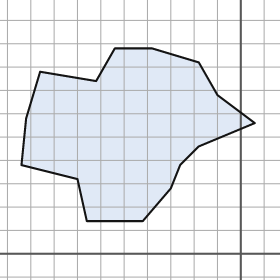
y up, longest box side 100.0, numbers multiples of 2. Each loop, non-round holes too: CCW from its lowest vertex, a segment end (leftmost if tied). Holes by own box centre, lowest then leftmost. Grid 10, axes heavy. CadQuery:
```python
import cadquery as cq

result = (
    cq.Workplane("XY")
    .moveTo(-66.0, 14.0)
    .lineTo(-42.0, 14.0)
    .lineTo(-30.0, 28.0)
    .lineTo(-26.0, 38.0)
    .lineTo(-18.0, 46.0)
    .lineTo(6.0, 56.0)
    .lineTo(-10.0, 68.0)
    .lineTo(-18.0, 82.0)
    .lineTo(-38.0, 88.0)
    .lineTo(-54.0, 88.0)
    .lineTo(-62.0, 74.0)
    .lineTo(-86.0, 78.0)
    .lineTo(-92.0, 58.0)
    .lineTo(-94.0, 38.0)
    .lineTo(-70.0, 32.0)
    .close()
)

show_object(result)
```